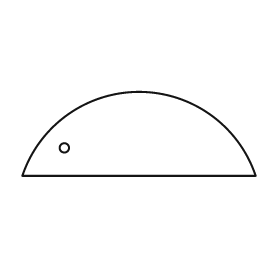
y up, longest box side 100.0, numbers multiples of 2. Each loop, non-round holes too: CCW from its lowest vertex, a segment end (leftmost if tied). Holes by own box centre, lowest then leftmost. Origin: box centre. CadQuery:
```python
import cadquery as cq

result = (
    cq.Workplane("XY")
    .moveTo(-50.0, -18.0)
    .lineTo(50.0, -18.0)
    .threePointArc((0.0, 18.0), (-50.0, -18.0))
    .close()
    .moveTo(-32.0, -6.0)
    .circle(2.0)
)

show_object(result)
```